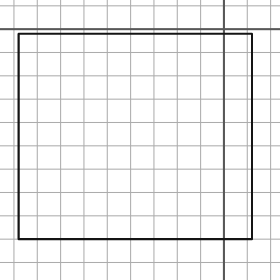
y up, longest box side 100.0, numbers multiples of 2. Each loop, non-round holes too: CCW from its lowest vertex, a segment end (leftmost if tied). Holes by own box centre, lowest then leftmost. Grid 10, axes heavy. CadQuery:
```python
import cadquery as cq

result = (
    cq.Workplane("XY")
    .moveTo(-88.0, -90.0)
    .lineTo(12.0, -90.0)
    .lineTo(12.0, -2.0)
    .lineTo(-88.0, -2.0)
    .close()
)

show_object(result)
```